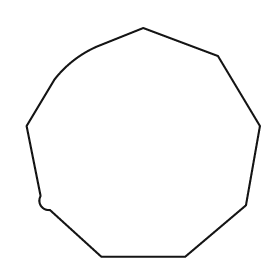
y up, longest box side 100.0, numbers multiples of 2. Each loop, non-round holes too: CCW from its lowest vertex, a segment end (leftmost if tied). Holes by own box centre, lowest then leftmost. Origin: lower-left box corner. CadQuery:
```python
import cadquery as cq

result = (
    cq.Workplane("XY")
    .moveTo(32.0, 0.0)
    .lineTo(68.0, 0.0)
    .lineTo(94.0, 22.0)
    .lineTo(100.0, 56.0)
    .lineTo(82.0, 86.0)
    .lineTo(50.0, 98.0)
    .lineTo(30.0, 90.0)
    .threePointArc((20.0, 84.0), (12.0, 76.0))
    .lineTo(0.0, 56.0)
    .lineTo(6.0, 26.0)
    .threePointArc((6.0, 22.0), (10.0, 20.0))
    .close()
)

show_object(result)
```